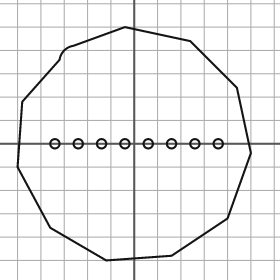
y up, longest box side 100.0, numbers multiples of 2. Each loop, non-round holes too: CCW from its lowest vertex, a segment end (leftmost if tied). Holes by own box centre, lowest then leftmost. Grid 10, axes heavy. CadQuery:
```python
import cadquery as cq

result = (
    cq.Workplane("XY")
    .moveTo(-12.0, -50.0)
    .lineTo(16.0, -48.0)
    .lineTo(40.0, -32.0)
    .lineTo(50.0, -4.0)
    .lineTo(44.0, 24.0)
    .lineTo(24.0, 44.0)
    .lineTo(-4.0, 50.0)
    .lineTo(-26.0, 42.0)
    .threePointArc((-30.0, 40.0), (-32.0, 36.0))
    .lineTo(-48.0, 18.0)
    .lineTo(-50.0, -10.0)
    .lineTo(-36.0, -36.0)
    .close()
    .moveTo(-34.0, 0.0)
    .circle(2.0)
    .moveTo(-24.0, 0.0)
    .circle(2.0)
    .moveTo(-14.0, 0.0)
    .circle(2.0)
    .moveTo(-4.0, 0.0)
    .circle(2.0)
    .moveTo(6.0, 0.0)
    .circle(2.0)
    .moveTo(16.0, 0.0)
    .circle(2.0)
    .moveTo(26.0, 0.0)
    .circle(2.0)
    .moveTo(36.0, 0.0)
    .circle(2.0)
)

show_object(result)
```